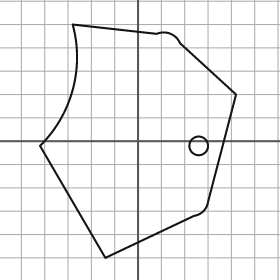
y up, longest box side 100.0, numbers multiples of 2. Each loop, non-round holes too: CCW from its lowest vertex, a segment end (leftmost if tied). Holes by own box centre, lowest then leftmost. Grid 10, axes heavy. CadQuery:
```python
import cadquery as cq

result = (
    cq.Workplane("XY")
    .moveTo(-14.0, -50.0)
    .lineTo(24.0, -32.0)
    .threePointArc((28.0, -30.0), (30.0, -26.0))
    .lineTo(42.0, 20.0)
    .lineTo(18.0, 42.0)
    .threePointArc((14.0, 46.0), (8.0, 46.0))
    .lineTo(-28.0, 50.0)
    .threePointArc((-28.0, 22.0), (-42.0, -2.0))
    .close()
    .moveTo(26.0, -2.0)
    .circle(4.0)
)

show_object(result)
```